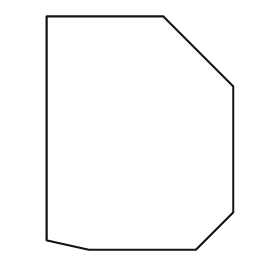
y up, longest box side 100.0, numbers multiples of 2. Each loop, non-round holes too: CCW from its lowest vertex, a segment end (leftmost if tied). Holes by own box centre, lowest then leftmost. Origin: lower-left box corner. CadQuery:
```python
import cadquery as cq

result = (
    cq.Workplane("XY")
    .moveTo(18.0, 0.0)
    .lineTo(64.0, 0.0)
    .lineTo(80.0, 16.0)
    .lineTo(80.0, 70.0)
    .lineTo(50.0, 100.0)
    .lineTo(0.0, 100.0)
    .lineTo(0.0, 4.0)
    .close()
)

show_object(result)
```